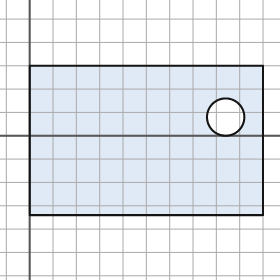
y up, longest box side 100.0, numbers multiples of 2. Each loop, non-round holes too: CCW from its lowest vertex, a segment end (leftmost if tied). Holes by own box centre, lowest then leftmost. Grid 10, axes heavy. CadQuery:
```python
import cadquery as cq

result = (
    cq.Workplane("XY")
    .moveTo(0.0, -34.0)
    .lineTo(100.0, -34.0)
    .lineTo(100.0, 30.0)
    .lineTo(0.0, 30.0)
    .close()
    .moveTo(84.0, 8.0)
    .circle(8.0)
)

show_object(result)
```